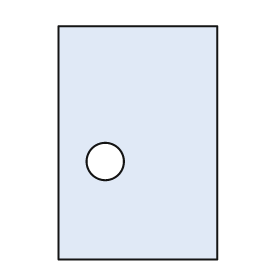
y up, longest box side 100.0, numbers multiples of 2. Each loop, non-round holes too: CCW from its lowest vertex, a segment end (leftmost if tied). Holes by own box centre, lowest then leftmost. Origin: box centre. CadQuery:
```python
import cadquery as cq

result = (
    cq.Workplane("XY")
    .moveTo(-34.0, -50.0)
    .lineTo(34.0, -50.0)
    .lineTo(34.0, 50.0)
    .lineTo(-34.0, 50.0)
    .close()
    .moveTo(-14.0, -8.0)
    .circle(8.0)
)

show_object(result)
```